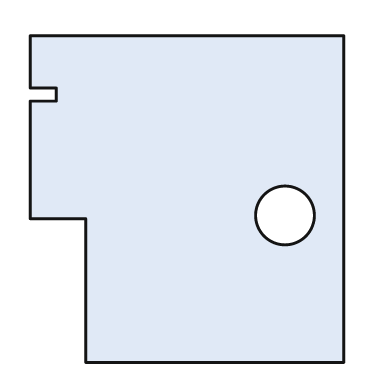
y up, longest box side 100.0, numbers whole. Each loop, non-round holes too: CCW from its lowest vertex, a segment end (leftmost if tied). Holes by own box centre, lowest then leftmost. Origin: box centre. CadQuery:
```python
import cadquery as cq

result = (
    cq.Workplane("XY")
    .moveTo(-31.0, -50.0)
    .lineTo(48.0, -50.0)
    .lineTo(48.0, 50.0)
    .lineTo(-48.0, 50.0)
    .lineTo(-48.0, 34.0)
    .lineTo(-40.0, 34.0)
    .lineTo(-40.0, 30.0)
    .lineTo(-48.0, 30.0)
    .lineTo(-48.0, -6.0)
    .lineTo(-31.0, -6.0)
    .close()
    .moveTo(30.0, -5.0)
    .circle(9.0)
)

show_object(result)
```